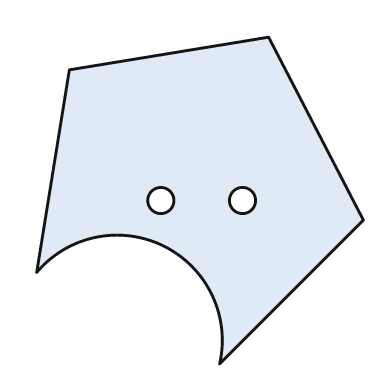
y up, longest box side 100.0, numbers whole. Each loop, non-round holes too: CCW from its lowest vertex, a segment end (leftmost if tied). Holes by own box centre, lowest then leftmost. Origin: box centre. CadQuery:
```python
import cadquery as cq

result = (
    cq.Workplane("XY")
    .moveTo(6.0, -50.0)
    .lineTo(50.0, -6.0)
    .lineTo(21.0, 50.0)
    .lineTo(-40.0, 40.0)
    .lineTo(-50.0, -22.0)
    .threePointArc((-11.0, -14.0), (6.0, -50.0))
    .close()
    .moveTo(-12.0, 0.0)
    .circle(4.0)
    .moveTo(13.0, 0.0)
    .circle(4.0)
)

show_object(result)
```